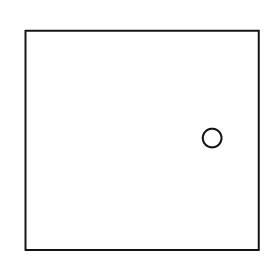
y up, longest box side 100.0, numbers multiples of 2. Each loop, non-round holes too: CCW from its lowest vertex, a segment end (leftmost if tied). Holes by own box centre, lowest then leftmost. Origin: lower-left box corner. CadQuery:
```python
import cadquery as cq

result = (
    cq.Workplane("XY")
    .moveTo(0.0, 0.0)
    .lineTo(100.0, 0.0)
    .lineTo(100.0, 94.0)
    .lineTo(0.0, 94.0)
    .close()
    .moveTo(80.0, 48.0)
    .circle(4.0)
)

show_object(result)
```